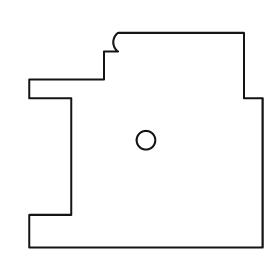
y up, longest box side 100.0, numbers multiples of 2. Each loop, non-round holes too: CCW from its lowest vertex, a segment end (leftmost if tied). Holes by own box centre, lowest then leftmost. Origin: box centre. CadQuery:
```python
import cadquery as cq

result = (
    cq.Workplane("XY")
    .moveTo(-50.0, -46.0)
    .lineTo(50.0, -46.0)
    .lineTo(50.0, 18.0)
    .lineTo(42.0, 18.0)
    .lineTo(42.0, 46.0)
    .lineTo(-12.0, 46.0)
    .threePointArc((-14.0, 42.0), (-12.0, 38.0))
    .lineTo(-18.0, 38.0)
    .lineTo(-18.0, 26.0)
    .lineTo(-50.0, 26.0)
    .lineTo(-50.0, 18.0)
    .lineTo(-32.0, 18.0)
    .lineTo(-32.0, -32.0)
    .lineTo(-50.0, -32.0)
    .close()
    .moveTo(0.0, 0.0)
    .circle(4.0)
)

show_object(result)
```